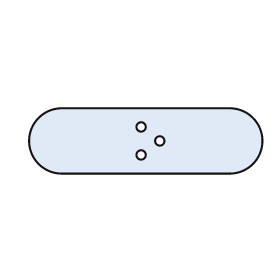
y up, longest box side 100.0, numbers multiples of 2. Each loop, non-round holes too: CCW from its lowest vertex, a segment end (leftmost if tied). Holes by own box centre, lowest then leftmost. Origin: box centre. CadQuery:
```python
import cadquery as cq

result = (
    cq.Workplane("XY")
    .moveTo(-36.0, -14.0)
    .lineTo(36.0, -14.0)
    .threePointArc((50.0, 0.0), (36.0, 14.0))
    .lineTo(-36.0, 14.0)
    .threePointArc((-50.0, 0.0), (-36.0, -14.0))
    .close()
    .moveTo(-2.0, -6.0)
    .circle(2.0)
    .moveTo(6.0, 0.0)
    .circle(2.0)
    .moveTo(-2.0, 6.0)
    .circle(2.0)
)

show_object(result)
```